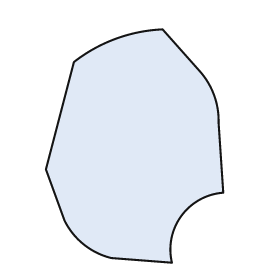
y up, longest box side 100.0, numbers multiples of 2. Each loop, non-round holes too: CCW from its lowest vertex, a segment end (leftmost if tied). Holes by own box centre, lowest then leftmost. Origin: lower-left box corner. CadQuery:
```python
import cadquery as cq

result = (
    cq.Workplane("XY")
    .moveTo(54.0, 0.0)
    .threePointArc((58.0, 20.0), (76.0, 30.0))
    .lineTo(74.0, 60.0)
    .threePointArc((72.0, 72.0), (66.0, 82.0))
    .lineTo(50.0, 100.0)
    .threePointArc((30.0, 96.0), (12.0, 86.0))
    .lineTo(0.0, 40.0)
    .lineTo(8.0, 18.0)
    .threePointArc((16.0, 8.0), (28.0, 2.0))
    .close()
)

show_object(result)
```